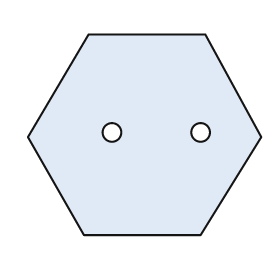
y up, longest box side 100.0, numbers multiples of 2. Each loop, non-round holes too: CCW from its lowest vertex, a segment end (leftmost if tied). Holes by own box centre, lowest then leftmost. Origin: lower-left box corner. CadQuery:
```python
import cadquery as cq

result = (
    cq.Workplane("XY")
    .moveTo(24.0, 0.0)
    .lineTo(74.0, 0.0)
    .lineTo(100.0, 42.0)
    .lineTo(76.0, 86.0)
    .lineTo(26.0, 86.0)
    .lineTo(0.0, 42.0)
    .close()
    .moveTo(36.0, 44.0)
    .circle(4.0)
    .moveTo(74.0, 44.0)
    .circle(4.0)
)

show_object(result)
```